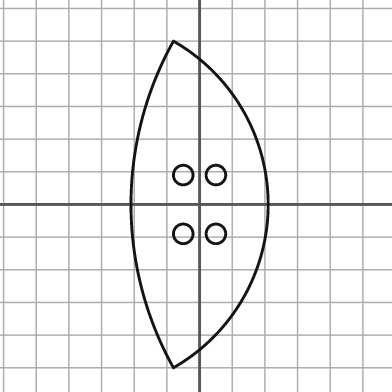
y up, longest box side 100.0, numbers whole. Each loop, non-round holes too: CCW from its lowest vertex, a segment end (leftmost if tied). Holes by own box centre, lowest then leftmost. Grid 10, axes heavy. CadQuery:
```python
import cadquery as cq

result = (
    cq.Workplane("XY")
    .moveTo(-8.0, -50.0)
    .threePointArc((21.0, 0.0), (-8.0, 50.0))
    .threePointArc((-21.0, 0.0), (-8.0, -50.0))
    .close()
    .moveTo(-5.0, -9.0)
    .circle(3.0)
    .moveTo(5.0, -9.0)
    .circle(3.0)
    .moveTo(-5.0, 9.0)
    .circle(3.0)
    .moveTo(5.0, 9.0)
    .circle(3.0)
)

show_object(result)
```